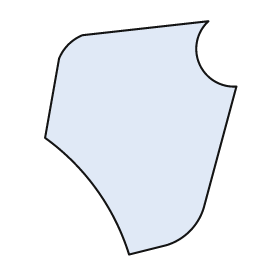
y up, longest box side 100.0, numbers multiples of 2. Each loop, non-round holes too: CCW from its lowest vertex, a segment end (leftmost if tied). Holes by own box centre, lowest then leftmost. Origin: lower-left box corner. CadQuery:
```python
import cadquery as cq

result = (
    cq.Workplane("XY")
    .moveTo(36.0, 0.0)
    .lineTo(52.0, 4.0)
    .threePointArc((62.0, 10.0), (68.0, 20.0))
    .lineTo(82.0, 72.0)
    .threePointArc((66.0, 82.0), (70.0, 100.0))
    .lineTo(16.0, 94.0)
    .threePointArc((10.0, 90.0), (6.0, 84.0))
    .lineTo(0.0, 50.0)
    .threePointArc((22.0, 28.0), (36.0, 0.0))
    .close()
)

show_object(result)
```